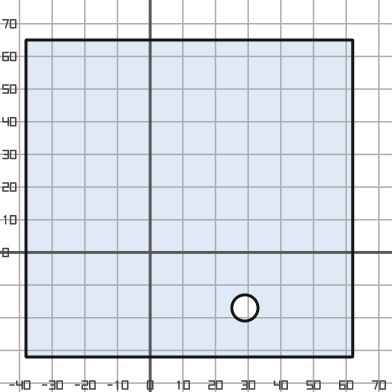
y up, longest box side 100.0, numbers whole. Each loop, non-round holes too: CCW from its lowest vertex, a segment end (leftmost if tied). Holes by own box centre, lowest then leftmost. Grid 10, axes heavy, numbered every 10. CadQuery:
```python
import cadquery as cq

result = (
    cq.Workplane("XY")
    .moveTo(-38.0, -32.0)
    .lineTo(62.0, -32.0)
    .lineTo(62.0, 65.0)
    .lineTo(-38.0, 65.0)
    .close()
    .moveTo(29.0, -17.0)
    .circle(4.0)
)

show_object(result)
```